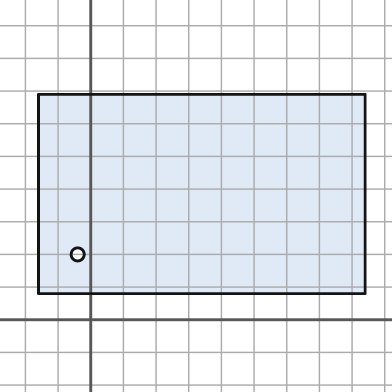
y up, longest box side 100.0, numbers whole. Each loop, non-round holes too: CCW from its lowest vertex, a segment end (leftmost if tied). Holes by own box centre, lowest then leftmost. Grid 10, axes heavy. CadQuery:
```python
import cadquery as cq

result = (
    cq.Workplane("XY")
    .moveTo(-16.0, 8.0)
    .lineTo(84.0, 8.0)
    .lineTo(84.0, 69.0)
    .lineTo(-16.0, 69.0)
    .close()
    .moveTo(-4.0, 20.0)
    .circle(2.0)
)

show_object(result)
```